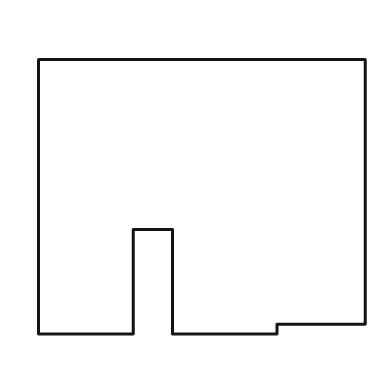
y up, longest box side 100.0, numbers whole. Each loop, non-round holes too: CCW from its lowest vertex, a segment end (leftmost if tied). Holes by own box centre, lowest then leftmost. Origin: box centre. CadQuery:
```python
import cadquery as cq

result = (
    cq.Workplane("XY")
    .moveTo(-50.0, -42.0)
    .lineTo(-21.0, -42.0)
    .lineTo(-21.0, -10.0)
    .lineTo(-9.0, -10.0)
    .lineTo(-9.0, -42.0)
    .lineTo(23.0, -42.0)
    .lineTo(23.0, -39.0)
    .lineTo(50.0, -39.0)
    .lineTo(50.0, 42.0)
    .lineTo(-50.0, 42.0)
    .close()
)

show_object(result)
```